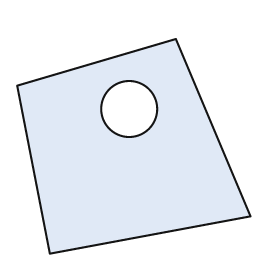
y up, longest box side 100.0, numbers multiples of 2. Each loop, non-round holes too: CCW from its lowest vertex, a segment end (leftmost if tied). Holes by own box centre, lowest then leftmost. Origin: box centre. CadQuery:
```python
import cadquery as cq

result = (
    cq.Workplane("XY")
    .moveTo(-36.0, -46.0)
    .lineTo(50.0, -30.0)
    .lineTo(18.0, 46.0)
    .lineTo(-50.0, 26.0)
    .close()
    .moveTo(-2.0, 16.0)
    .circle(12.0)
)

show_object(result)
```